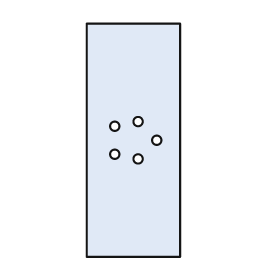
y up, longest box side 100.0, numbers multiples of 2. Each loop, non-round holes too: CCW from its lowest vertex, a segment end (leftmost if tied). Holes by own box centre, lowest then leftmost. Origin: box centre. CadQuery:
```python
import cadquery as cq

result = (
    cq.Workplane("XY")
    .moveTo(-20.0, -50.0)
    .lineTo(20.0, -50.0)
    .lineTo(20.0, 50.0)
    .lineTo(-20.0, 50.0)
    .close()
    .moveTo(2.0, -8.0)
    .circle(2.0)
    .moveTo(-8.0, -6.0)
    .circle(2.0)
    .moveTo(10.0, 0.0)
    .circle(2.0)
    .moveTo(-8.0, 6.0)
    .circle(2.0)
    .moveTo(2.0, 8.0)
    .circle(2.0)
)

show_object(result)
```